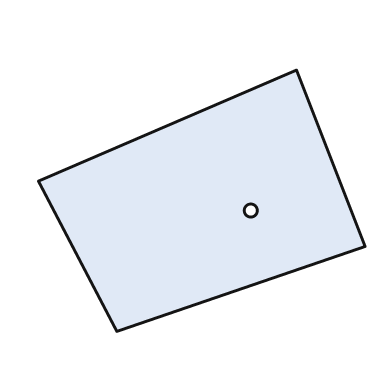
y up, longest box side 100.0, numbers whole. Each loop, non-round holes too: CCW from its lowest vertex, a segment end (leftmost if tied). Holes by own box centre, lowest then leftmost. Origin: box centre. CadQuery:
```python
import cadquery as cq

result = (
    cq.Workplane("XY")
    .moveTo(-26.0, -40.0)
    .lineTo(50.0, -14.0)
    .lineTo(29.0, 40.0)
    .lineTo(-50.0, 6.0)
    .close()
    .moveTo(15.0, -3.0)
    .circle(2.0)
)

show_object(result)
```